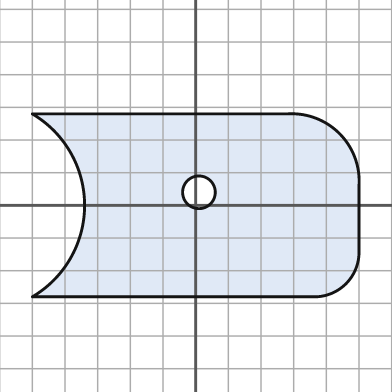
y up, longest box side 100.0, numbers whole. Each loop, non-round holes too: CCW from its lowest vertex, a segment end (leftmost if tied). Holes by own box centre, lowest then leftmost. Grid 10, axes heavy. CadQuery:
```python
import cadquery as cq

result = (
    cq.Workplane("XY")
    .moveTo(-50.0, -28.0)
    .lineTo(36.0, -28.0)
    .threePointArc((46.0, -24.0), (50.0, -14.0))
    .lineTo(50.0, 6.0)
    .threePointArc((44.0, 22.0), (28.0, 28.0))
    .lineTo(-50.0, 28.0)
    .threePointArc((-34.0, 0.0), (-50.0, -28.0))
    .close()
    .moveTo(1.0, 4.0)
    .circle(5.0)
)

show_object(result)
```